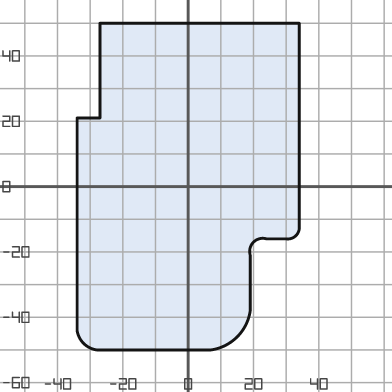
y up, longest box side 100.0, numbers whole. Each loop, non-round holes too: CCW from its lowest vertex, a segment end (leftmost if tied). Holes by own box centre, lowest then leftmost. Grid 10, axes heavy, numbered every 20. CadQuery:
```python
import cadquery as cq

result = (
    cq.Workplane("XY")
    .moveTo(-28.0, -50.0)
    .lineTo(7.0, -50.0)
    .threePointArc((15.0, -46.0), (19.0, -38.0))
    .lineTo(19.0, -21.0)
    .threePointArc((20.0, -17.0), (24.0, -16.0))
    .lineTo(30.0, -16.0)
    .threePointArc((33.0, -15.0), (34.0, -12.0))
    .lineTo(34.0, 50.0)
    .lineTo(-27.0, 50.0)
    .lineTo(-27.0, 21.0)
    .lineTo(-34.0, 21.0)
    .lineTo(-34.0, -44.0)
    .threePointArc((-32.0, -48.0), (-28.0, -50.0))
    .close()
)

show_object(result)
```